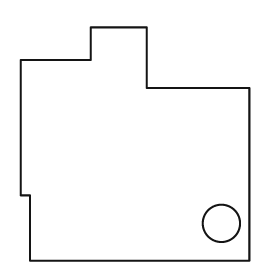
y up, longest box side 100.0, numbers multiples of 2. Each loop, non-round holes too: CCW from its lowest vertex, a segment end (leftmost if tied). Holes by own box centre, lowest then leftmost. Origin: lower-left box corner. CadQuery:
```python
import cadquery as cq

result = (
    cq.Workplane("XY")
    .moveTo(4.0, 0.0)
    .lineTo(98.0, 0.0)
    .lineTo(98.0, 74.0)
    .lineTo(54.0, 74.0)
    .lineTo(54.0, 100.0)
    .lineTo(30.0, 100.0)
    .lineTo(30.0, 86.0)
    .lineTo(0.0, 86.0)
    .lineTo(0.0, 28.0)
    .lineTo(4.0, 28.0)
    .close()
    .moveTo(86.0, 16.0)
    .circle(8.0)
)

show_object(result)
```